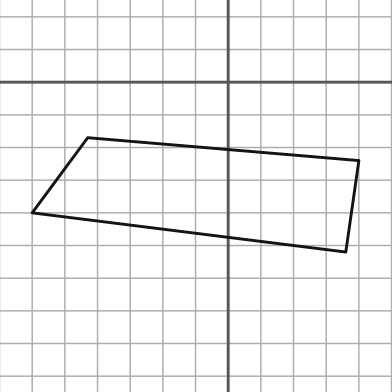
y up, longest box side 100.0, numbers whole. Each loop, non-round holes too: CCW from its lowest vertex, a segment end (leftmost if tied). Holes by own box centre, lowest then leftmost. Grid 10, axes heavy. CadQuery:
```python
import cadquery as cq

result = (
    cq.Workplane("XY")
    .moveTo(36.0, -52.0)
    .lineTo(40.0, -24.0)
    .lineTo(-43.0, -17.0)
    .lineTo(-60.0, -40.0)
    .close()
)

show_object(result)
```